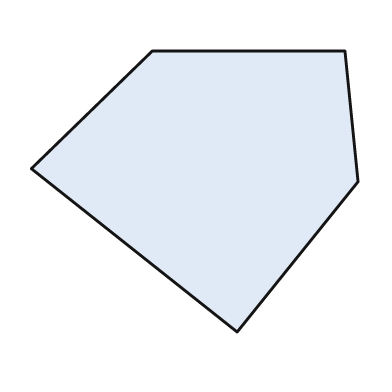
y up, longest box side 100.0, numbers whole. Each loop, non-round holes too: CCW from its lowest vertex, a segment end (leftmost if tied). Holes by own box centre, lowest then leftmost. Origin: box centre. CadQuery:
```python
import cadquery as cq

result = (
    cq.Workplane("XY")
    .moveTo(13.0, -43.0)
    .lineTo(50.0, 3.0)
    .lineTo(46.0, 43.0)
    .lineTo(-13.0, 43.0)
    .lineTo(-50.0, 7.0)
    .close()
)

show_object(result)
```